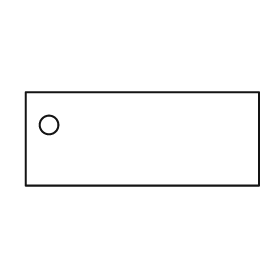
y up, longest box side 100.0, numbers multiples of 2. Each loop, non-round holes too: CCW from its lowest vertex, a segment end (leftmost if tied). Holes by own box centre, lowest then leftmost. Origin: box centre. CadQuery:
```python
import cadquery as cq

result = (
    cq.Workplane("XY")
    .moveTo(-50.0, -20.0)
    .lineTo(50.0, -20.0)
    .lineTo(50.0, 20.0)
    .lineTo(-50.0, 20.0)
    .close()
    .moveTo(-40.0, 6.0)
    .circle(4.0)
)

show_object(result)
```